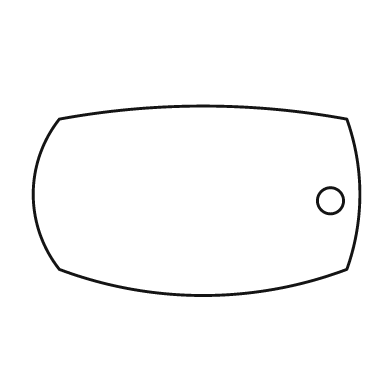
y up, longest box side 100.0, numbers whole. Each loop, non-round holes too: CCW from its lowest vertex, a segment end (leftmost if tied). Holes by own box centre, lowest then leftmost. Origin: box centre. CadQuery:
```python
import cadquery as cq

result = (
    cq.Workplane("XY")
    .moveTo(-42.0, -21.0)
    .threePointArc((2.0, -29.0), (46.0, -21.0))
    .threePointArc((50.0, 2.0), (46.0, 25.0))
    .threePointArc((2.0, 29.0), (-42.0, 25.0))
    .threePointArc((-50.0, 2.0), (-42.0, -21.0))
    .close()
    .moveTo(41.0, 0.0)
    .circle(4.0)
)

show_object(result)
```